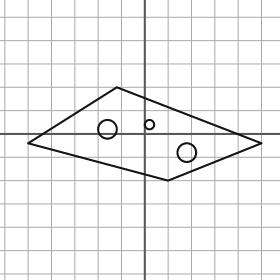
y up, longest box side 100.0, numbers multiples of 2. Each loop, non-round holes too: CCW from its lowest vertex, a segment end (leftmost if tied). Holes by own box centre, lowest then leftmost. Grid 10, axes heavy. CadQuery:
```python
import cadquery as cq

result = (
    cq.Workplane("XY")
    .moveTo(10.0, -20.0)
    .lineTo(50.0, -4.0)
    .lineTo(-12.0, 20.0)
    .lineTo(-50.0, -4.0)
    .close()
    .moveTo(18.0, -8.0)
    .circle(4.0)
    .moveTo(-16.0, 2.0)
    .circle(4.0)
    .moveTo(2.0, 4.0)
    .circle(2.0)
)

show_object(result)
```